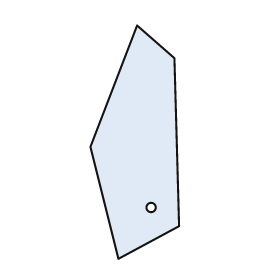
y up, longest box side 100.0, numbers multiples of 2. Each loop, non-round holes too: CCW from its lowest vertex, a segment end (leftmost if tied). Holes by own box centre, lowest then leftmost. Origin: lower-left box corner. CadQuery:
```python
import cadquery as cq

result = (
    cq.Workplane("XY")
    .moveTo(12.0, 0.0)
    .lineTo(38.0, 14.0)
    .lineTo(36.0, 86.0)
    .lineTo(20.0, 100.0)
    .lineTo(0.0, 48.0)
    .close()
    .moveTo(26.0, 22.0)
    .circle(2.0)
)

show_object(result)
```